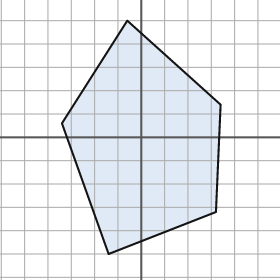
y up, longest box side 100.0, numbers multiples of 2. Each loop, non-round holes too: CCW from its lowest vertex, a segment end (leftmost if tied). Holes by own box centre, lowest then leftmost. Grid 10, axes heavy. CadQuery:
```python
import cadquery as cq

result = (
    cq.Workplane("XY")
    .moveTo(-14.0, -50.0)
    .lineTo(32.0, -32.0)
    .lineTo(34.0, 14.0)
    .lineTo(-6.0, 50.0)
    .lineTo(-34.0, 6.0)
    .close()
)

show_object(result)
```